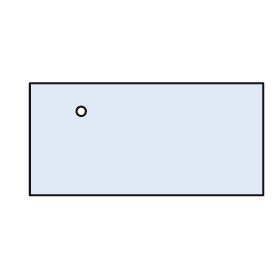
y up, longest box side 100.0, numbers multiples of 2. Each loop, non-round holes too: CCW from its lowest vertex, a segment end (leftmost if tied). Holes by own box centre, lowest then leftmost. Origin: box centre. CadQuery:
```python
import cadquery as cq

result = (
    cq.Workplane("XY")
    .moveTo(-50.0, -24.0)
    .lineTo(50.0, -24.0)
    .lineTo(50.0, 24.0)
    .lineTo(-50.0, 24.0)
    .close()
    .moveTo(-28.0, 12.0)
    .circle(2.0)
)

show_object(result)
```